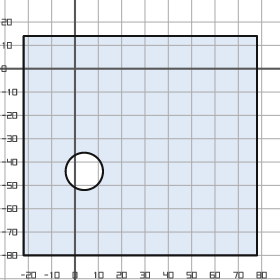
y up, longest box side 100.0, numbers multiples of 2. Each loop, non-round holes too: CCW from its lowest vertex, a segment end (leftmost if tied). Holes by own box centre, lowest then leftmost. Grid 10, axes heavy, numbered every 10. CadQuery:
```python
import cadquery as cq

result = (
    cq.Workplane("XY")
    .moveTo(-22.0, -80.0)
    .lineTo(78.0, -80.0)
    .lineTo(78.0, 14.0)
    .lineTo(-22.0, 14.0)
    .close()
    .moveTo(4.0, -44.0)
    .circle(8.0)
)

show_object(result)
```